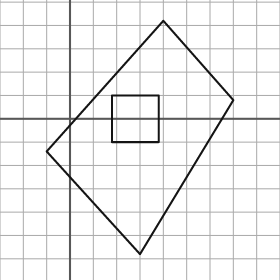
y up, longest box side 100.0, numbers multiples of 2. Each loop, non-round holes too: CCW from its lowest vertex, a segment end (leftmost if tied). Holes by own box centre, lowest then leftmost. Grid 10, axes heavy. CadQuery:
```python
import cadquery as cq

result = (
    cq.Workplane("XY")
    .moveTo(30.0, -58.0)
    .lineTo(70.0, 8.0)
    .lineTo(40.0, 42.0)
    .lineTo(-10.0, -14.0)
    .close()
    .moveTo(18.0, -10.0)
    .lineTo(38.0, -10.0)
    .lineTo(38.0, 10.0)
    .lineTo(18.0, 10.0)
    .close()
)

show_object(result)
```